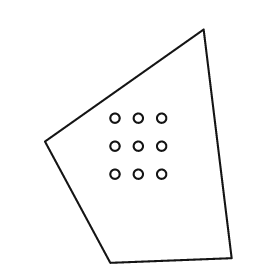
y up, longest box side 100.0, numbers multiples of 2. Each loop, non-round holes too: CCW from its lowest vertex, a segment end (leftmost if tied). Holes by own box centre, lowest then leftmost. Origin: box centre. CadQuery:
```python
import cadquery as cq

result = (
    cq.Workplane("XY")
    .moveTo(-12.0, -50.0)
    .lineTo(40.0, -48.0)
    .lineTo(28.0, 50.0)
    .lineTo(-40.0, 2.0)
    .close()
    .moveTo(-10.0, -12.0)
    .circle(2.0)
    .moveTo(0.0, -12.0)
    .circle(2.0)
    .moveTo(10.0, -12.0)
    .circle(2.0)
    .moveTo(-10.0, 0.0)
    .circle(2.0)
    .moveTo(0.0, 0.0)
    .circle(2.0)
    .moveTo(10.0, 0.0)
    .circle(2.0)
    .moveTo(-10.0, 12.0)
    .circle(2.0)
    .moveTo(0.0, 12.0)
    .circle(2.0)
    .moveTo(10.0, 12.0)
    .circle(2.0)
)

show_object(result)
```